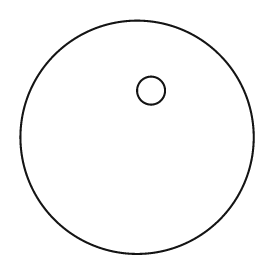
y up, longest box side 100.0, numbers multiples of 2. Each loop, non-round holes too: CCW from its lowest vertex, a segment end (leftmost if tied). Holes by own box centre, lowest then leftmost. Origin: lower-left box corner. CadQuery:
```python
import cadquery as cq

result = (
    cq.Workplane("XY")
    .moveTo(50.0, 50.0)
    .circle(50.0)
    .moveTo(56.0, 70.0)
    .circle(6.0)
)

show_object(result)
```